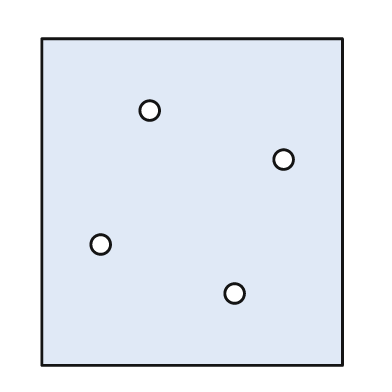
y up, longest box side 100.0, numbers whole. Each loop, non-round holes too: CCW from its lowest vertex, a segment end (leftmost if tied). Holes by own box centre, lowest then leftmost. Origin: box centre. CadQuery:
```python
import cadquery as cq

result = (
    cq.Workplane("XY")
    .moveTo(-46.0, -50.0)
    .lineTo(46.0, -50.0)
    .lineTo(46.0, 50.0)
    .lineTo(-46.0, 50.0)
    .close()
    .moveTo(13.0, -28.0)
    .circle(3.0)
    .moveTo(-28.0, -13.0)
    .circle(3.0)
    .moveTo(28.0, 13.0)
    .circle(3.0)
    .moveTo(-13.0, 28.0)
    .circle(3.0)
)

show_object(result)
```